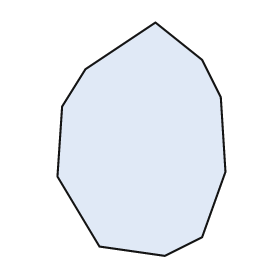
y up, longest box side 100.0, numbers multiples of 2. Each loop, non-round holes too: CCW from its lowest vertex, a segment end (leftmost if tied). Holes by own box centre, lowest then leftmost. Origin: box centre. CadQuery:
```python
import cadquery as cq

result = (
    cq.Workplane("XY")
    .moveTo(10.0, -50.0)
    .lineTo(26.0, -42.0)
    .lineTo(36.0, -14.0)
    .lineTo(34.0, 18.0)
    .lineTo(26.0, 34.0)
    .lineTo(6.0, 50.0)
    .lineTo(-24.0, 30.0)
    .lineTo(-34.0, 14.0)
    .lineTo(-36.0, -16.0)
    .lineTo(-18.0, -46.0)
    .close()
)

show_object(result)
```